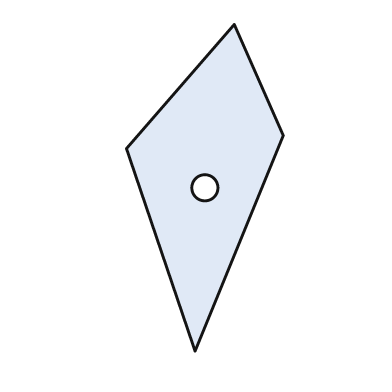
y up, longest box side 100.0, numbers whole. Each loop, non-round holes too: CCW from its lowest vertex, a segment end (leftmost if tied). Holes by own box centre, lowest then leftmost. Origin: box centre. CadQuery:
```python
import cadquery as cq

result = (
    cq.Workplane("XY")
    .moveTo(-3.0, -50.0)
    .lineTo(24.0, 16.0)
    .lineTo(9.0, 50.0)
    .lineTo(-24.0, 12.0)
    .close()
    .moveTo(0.0, 0.0)
    .circle(4.0)
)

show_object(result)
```